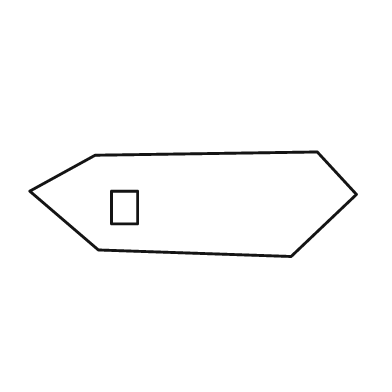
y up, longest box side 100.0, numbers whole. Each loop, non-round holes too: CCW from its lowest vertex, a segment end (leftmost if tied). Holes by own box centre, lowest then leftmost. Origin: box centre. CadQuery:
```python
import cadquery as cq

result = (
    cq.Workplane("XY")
    .moveTo(30.0, -16.0)
    .lineTo(50.0, 3.0)
    .lineTo(38.0, 16.0)
    .lineTo(-30.0, 15.0)
    .lineTo(-50.0, 4.0)
    .lineTo(-29.0, -14.0)
    .close()
    .moveTo(-25.0, -6.0)
    .lineTo(-17.0, -6.0)
    .lineTo(-17.0, 4.0)
    .lineTo(-25.0, 4.0)
    .close()
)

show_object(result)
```